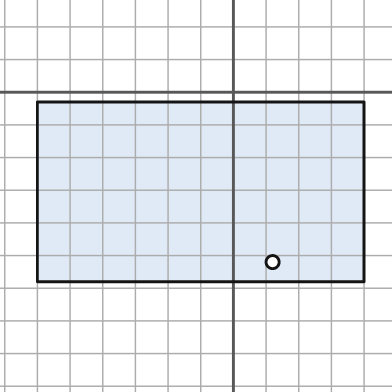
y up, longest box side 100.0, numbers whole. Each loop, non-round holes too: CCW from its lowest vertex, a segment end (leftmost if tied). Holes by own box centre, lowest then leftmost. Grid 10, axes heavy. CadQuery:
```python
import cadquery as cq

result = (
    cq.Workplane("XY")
    .moveTo(-60.0, -58.0)
    .lineTo(40.0, -58.0)
    .lineTo(40.0, -3.0)
    .lineTo(-60.0, -3.0)
    .close()
    .moveTo(12.0, -52.0)
    .circle(2.0)
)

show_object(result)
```